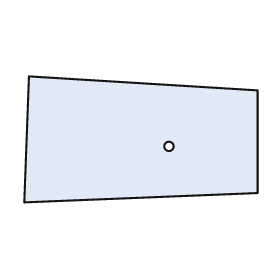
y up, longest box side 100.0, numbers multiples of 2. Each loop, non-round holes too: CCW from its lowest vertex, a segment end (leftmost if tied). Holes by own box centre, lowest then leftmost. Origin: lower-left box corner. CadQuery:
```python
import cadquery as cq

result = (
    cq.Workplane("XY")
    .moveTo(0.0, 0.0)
    .lineTo(100.0, 4.0)
    .lineTo(100.0, 48.0)
    .lineTo(2.0, 54.0)
    .close()
    .moveTo(62.0, 24.0)
    .circle(2.0)
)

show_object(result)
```